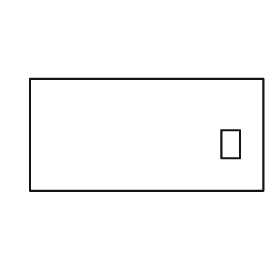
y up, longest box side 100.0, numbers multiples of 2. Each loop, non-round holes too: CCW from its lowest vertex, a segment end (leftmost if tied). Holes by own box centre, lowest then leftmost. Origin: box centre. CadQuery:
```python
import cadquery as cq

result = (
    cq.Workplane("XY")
    .moveTo(-50.0, -24.0)
    .lineTo(50.0, -24.0)
    .lineTo(50.0, 24.0)
    .lineTo(-50.0, 24.0)
    .close()
    .moveTo(32.0, -10.0)
    .lineTo(40.0, -10.0)
    .lineTo(40.0, 2.0)
    .lineTo(32.0, 2.0)
    .close()
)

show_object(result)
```